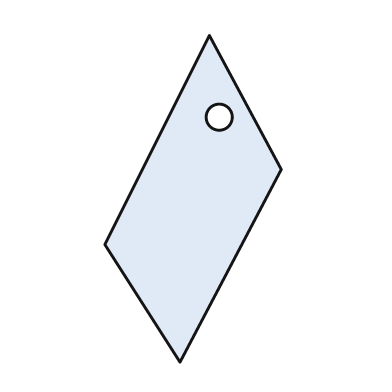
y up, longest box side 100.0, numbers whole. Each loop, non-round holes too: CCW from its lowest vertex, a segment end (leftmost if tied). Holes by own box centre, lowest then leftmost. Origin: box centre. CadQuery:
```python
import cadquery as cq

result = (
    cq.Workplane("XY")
    .moveTo(-4.0, -50.0)
    .lineTo(27.0, 9.0)
    .lineTo(5.0, 50.0)
    .lineTo(-27.0, -14.0)
    .close()
    .moveTo(8.0, 25.0)
    .circle(4.0)
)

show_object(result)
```